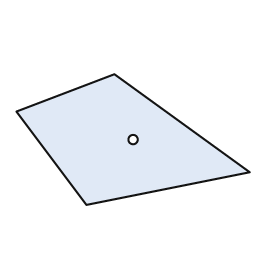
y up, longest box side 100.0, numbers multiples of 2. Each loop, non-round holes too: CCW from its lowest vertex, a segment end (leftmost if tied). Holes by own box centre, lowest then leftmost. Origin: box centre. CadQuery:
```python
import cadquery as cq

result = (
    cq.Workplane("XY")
    .moveTo(-20.0, -28.0)
    .lineTo(50.0, -14.0)
    .lineTo(-8.0, 28.0)
    .lineTo(-50.0, 12.0)
    .close()
    .moveTo(0.0, 0.0)
    .circle(2.0)
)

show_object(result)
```